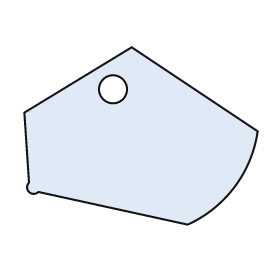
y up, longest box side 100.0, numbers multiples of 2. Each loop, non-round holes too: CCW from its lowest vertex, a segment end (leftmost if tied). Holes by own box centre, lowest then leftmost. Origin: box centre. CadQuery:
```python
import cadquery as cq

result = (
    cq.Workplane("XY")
    .moveTo(20.0, -38.0)
    .threePointArc((40.0, -22.0), (50.0, 2.0))
    .lineTo(-4.0, 38.0)
    .lineTo(-50.0, 10.0)
    .lineTo(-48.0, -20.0)
    .threePointArc((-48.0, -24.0), (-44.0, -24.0))
    .close()
    .moveTo(-12.0, 20.0)
    .circle(6.0)
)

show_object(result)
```